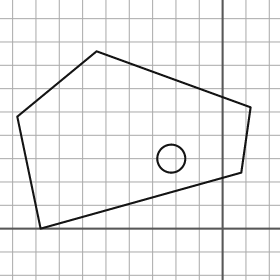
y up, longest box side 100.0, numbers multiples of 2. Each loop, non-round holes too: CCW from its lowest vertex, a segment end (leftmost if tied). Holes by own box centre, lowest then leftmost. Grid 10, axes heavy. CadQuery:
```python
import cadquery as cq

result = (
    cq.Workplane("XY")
    .moveTo(-78.0, 0.0)
    .lineTo(8.0, 24.0)
    .lineTo(12.0, 52.0)
    .lineTo(-54.0, 76.0)
    .lineTo(-88.0, 48.0)
    .close()
    .moveTo(-22.0, 30.0)
    .circle(6.0)
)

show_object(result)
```